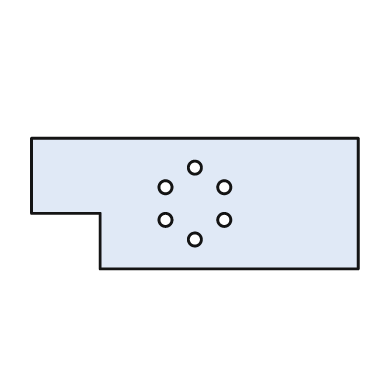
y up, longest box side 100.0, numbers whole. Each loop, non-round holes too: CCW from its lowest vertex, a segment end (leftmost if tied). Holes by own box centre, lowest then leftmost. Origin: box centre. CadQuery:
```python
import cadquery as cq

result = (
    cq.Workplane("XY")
    .moveTo(-29.0, -20.0)
    .lineTo(50.0, -20.0)
    .lineTo(50.0, 20.0)
    .lineTo(-50.0, 20.0)
    .lineTo(-50.0, -3.0)
    .lineTo(-29.0, -3.0)
    .close()
    .moveTo(0.0, -11.0)
    .circle(2.0)
    .moveTo(-9.0, -5.0)
    .circle(2.0)
    .moveTo(9.0, -5.0)
    .circle(2.0)
    .moveTo(-9.0, 5.0)
    .circle(2.0)
    .moveTo(9.0, 5.0)
    .circle(2.0)
    .moveTo(0.0, 11.0)
    .circle(2.0)
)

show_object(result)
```